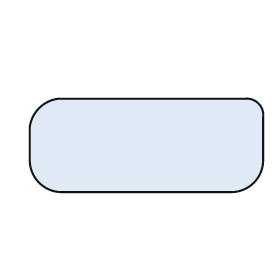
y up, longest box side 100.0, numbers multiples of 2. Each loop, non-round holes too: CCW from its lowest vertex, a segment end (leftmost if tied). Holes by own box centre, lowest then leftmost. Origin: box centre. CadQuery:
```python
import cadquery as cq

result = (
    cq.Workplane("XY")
    .moveTo(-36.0, -20.0)
    .lineTo(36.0, -20.0)
    .threePointArc((46.0, -16.0), (50.0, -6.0))
    .lineTo(50.0, 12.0)
    .threePointArc((48.0, 18.0), (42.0, 20.0))
    .lineTo(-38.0, 20.0)
    .threePointArc((-46.0, 16.0), (-50.0, 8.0))
    .lineTo(-50.0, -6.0)
    .threePointArc((-46.0, -16.0), (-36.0, -20.0))
    .close()
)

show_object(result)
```